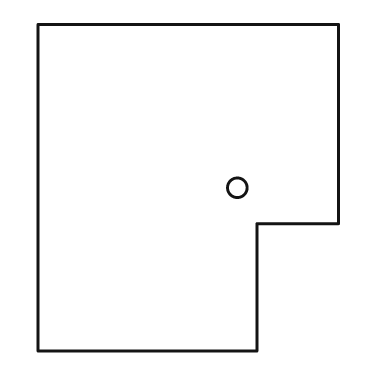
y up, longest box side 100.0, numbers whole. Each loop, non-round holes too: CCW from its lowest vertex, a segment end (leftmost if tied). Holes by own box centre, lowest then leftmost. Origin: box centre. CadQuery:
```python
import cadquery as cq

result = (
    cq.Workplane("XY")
    .moveTo(-46.0, -50.0)
    .lineTo(21.0, -50.0)
    .lineTo(21.0, -11.0)
    .lineTo(46.0, -11.0)
    .lineTo(46.0, 50.0)
    .lineTo(-46.0, 50.0)
    .close()
    .moveTo(15.0, 0.0)
    .circle(3.0)
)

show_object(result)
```